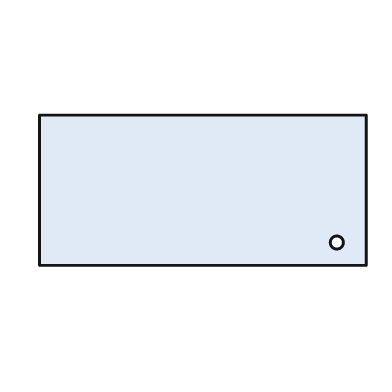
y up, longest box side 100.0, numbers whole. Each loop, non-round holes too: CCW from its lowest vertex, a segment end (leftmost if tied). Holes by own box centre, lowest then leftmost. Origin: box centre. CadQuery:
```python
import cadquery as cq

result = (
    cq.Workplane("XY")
    .moveTo(-50.0, -23.0)
    .lineTo(50.0, -23.0)
    .lineTo(50.0, 23.0)
    .lineTo(-50.0, 23.0)
    .close()
    .moveTo(41.0, -16.0)
    .circle(2.0)
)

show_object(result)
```